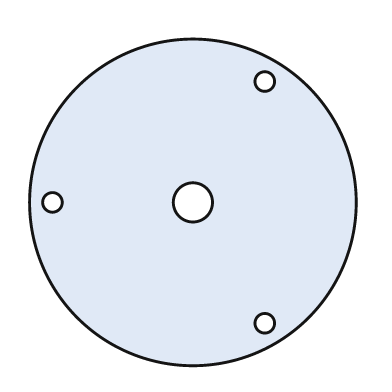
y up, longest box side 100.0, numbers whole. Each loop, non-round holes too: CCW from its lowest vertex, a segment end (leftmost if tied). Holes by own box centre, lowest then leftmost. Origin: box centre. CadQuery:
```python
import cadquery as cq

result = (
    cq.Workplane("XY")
    .moveTo(0.0, 0.0)
    .circle(50.0)
    .moveTo(22.0, -37.0)
    .circle(3.0)
    .moveTo(-43.0, 0.0)
    .circle(3.0)
    .moveTo(0.0, 0.0)
    .circle(6.0)
    .moveTo(22.0, 37.0)
    .circle(3.0)
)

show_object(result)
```